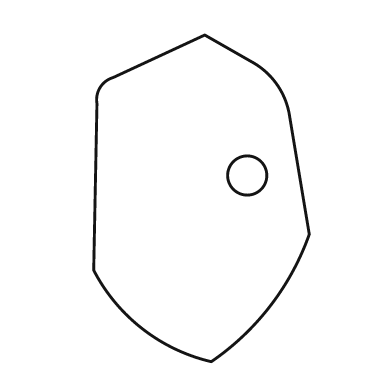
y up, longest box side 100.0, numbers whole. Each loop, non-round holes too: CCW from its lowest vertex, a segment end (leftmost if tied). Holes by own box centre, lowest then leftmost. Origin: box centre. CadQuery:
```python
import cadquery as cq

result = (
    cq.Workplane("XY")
    .moveTo(3.0, -50.0)
    .threePointArc((21.0, -33.0), (33.0, -11.0))
    .lineTo(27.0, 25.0)
    .threePointArc((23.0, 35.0), (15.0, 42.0))
    .lineTo(1.0, 50.0)
    .lineTo(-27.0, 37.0)
    .threePointArc((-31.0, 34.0), (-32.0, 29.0))
    .lineTo(-33.0, -22.0)
    .threePointArc((-18.0, -40.0), (3.0, -50.0))
    .close()
    .moveTo(14.0, 7.0)
    .circle(6.0)
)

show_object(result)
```